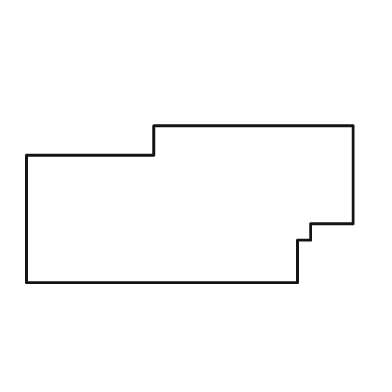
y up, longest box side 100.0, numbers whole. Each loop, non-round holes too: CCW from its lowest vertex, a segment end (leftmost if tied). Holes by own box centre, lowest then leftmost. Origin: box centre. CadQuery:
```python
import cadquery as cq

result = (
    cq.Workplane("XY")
    .moveTo(-50.0, -24.0)
    .lineTo(33.0, -24.0)
    .lineTo(33.0, -11.0)
    .lineTo(37.0, -11.0)
    .lineTo(37.0, -6.0)
    .lineTo(50.0, -6.0)
    .lineTo(50.0, 24.0)
    .lineTo(-11.0, 24.0)
    .lineTo(-11.0, 15.0)
    .lineTo(-50.0, 15.0)
    .close()
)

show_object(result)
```